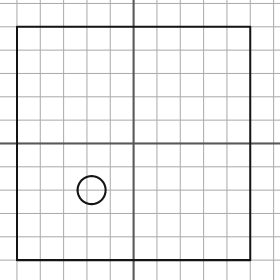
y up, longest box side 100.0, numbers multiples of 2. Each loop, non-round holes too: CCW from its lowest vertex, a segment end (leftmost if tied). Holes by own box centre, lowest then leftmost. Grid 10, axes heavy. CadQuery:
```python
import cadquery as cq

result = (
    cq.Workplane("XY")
    .moveTo(-50.0, -50.0)
    .lineTo(50.0, -50.0)
    .lineTo(50.0, 50.0)
    .lineTo(-50.0, 50.0)
    .close()
    .moveTo(-18.0, -20.0)
    .circle(6.0)
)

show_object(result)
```